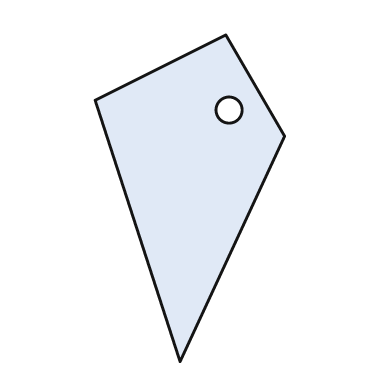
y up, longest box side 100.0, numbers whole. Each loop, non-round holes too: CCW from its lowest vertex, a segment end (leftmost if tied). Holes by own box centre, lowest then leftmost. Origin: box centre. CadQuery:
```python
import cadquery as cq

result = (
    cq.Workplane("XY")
    .moveTo(-3.0, -50.0)
    .lineTo(29.0, 19.0)
    .lineTo(11.0, 50.0)
    .lineTo(-29.0, 30.0)
    .close()
    .moveTo(12.0, 27.0)
    .circle(4.0)
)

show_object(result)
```